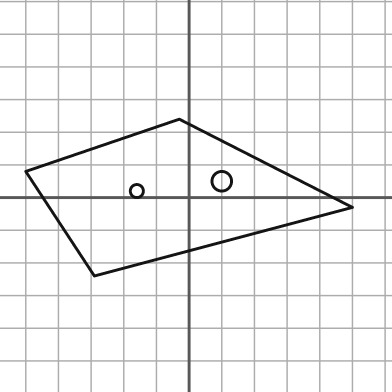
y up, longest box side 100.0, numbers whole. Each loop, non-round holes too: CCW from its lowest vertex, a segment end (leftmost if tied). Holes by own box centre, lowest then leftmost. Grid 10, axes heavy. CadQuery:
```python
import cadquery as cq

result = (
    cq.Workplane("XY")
    .moveTo(-29.0, -24.0)
    .lineTo(50.0, -3.0)
    .lineTo(-3.0, 24.0)
    .lineTo(-50.0, 8.0)
    .close()
    .moveTo(-16.0, 2.0)
    .circle(2.0)
    .moveTo(10.0, 5.0)
    .circle(3.0)
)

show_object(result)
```